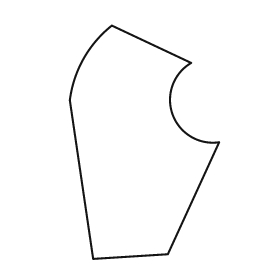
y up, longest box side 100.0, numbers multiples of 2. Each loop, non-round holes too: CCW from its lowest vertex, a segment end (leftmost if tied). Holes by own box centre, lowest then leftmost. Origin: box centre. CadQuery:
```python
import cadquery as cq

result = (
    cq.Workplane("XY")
    .moveTo(-22.0, -50.0)
    .lineTo(10.0, -48.0)
    .lineTo(32.0, 0.0)
    .threePointArc((12.0, 12.0), (20.0, 34.0))
    .lineTo(-14.0, 50.0)
    .threePointArc((-26.0, 36.0), (-32.0, 18.0))
    .close()
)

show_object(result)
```